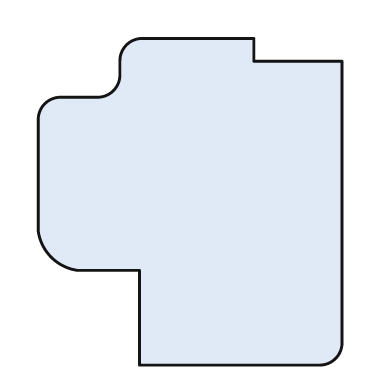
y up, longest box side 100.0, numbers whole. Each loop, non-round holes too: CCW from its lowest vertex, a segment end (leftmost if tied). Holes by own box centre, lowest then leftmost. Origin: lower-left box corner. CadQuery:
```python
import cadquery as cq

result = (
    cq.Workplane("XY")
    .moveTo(31.0, 0.0)
    .lineTo(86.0, 0.0)
    .threePointArc((91.0, 2.0), (93.0, 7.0))
    .lineTo(93.0, 93.0)
    .lineTo(66.0, 93.0)
    .lineTo(66.0, 100.0)
    .lineTo(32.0, 100.0)
    .threePointArc((27.0, 98.0), (25.0, 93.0))
    .lineTo(25.0, 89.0)
    .threePointArc((23.0, 84.0), (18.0, 82.0))
    .lineTo(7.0, 82.0)
    .threePointArc((2.0, 80.0), (0.0, 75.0))
    .lineTo(0.0, 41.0)
    .threePointArc((4.0, 33.0), (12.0, 29.0))
    .lineTo(31.0, 29.0)
    .close()
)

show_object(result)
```